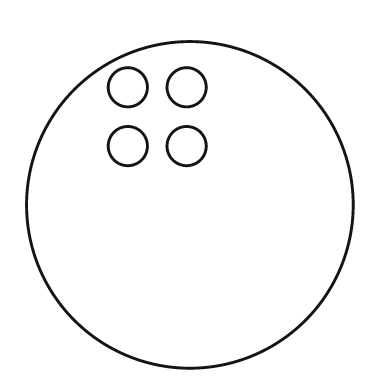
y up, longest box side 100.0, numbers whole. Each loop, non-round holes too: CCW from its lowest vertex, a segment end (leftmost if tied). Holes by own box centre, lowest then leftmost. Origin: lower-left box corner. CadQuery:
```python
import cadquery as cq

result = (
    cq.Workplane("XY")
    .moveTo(50.0, 50.0)
    .circle(50.0)
    .moveTo(31.0, 68.0)
    .circle(6.0)
    .moveTo(49.0, 68.0)
    .circle(6.0)
    .moveTo(31.0, 86.0)
    .circle(6.0)
    .moveTo(49.0, 86.0)
    .circle(6.0)
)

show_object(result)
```